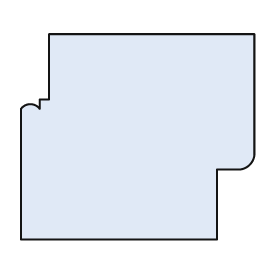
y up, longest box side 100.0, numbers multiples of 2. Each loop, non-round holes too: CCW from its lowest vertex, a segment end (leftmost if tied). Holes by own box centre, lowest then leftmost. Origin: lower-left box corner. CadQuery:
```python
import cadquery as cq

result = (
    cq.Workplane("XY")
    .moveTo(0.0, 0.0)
    .lineTo(84.0, 0.0)
    .lineTo(84.0, 30.0)
    .lineTo(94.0, 30.0)
    .threePointArc((98.0, 32.0), (100.0, 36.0))
    .lineTo(100.0, 88.0)
    .lineTo(12.0, 88.0)
    .lineTo(12.0, 60.0)
    .lineTo(8.0, 60.0)
    .lineTo(8.0, 56.0)
    .threePointArc((4.0, 58.0), (0.0, 56.0))
    .close()
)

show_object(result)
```